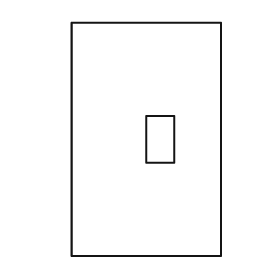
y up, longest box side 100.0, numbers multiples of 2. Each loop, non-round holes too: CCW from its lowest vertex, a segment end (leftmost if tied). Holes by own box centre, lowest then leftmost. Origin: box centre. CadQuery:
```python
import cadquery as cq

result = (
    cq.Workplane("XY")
    .moveTo(-32.0, -50.0)
    .lineTo(32.0, -50.0)
    .lineTo(32.0, 50.0)
    .lineTo(-32.0, 50.0)
    .close()
    .moveTo(0.0, -10.0)
    .lineTo(12.0, -10.0)
    .lineTo(12.0, 10.0)
    .lineTo(0.0, 10.0)
    .close()
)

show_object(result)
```